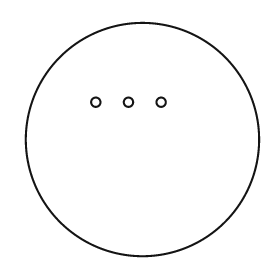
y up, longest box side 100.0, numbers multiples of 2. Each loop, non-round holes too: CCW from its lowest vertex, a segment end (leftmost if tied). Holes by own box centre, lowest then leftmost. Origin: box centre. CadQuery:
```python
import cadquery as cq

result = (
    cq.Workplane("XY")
    .moveTo(0.0, 0.0)
    .circle(50.0)
    .moveTo(-20.0, 16.0)
    .circle(2.0)
    .moveTo(-6.0, 16.0)
    .circle(2.0)
    .moveTo(8.0, 16.0)
    .circle(2.0)
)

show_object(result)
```